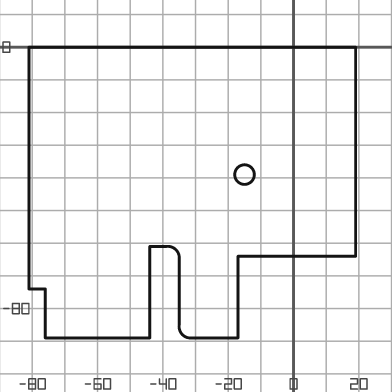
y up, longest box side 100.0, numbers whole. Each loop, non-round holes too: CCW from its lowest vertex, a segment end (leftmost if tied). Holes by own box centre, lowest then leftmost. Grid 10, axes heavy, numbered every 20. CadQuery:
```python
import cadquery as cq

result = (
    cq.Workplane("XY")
    .moveTo(-76.0, -89.0)
    .lineTo(-44.0, -89.0)
    .lineTo(-44.0, -61.0)
    .lineTo(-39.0, -61.0)
    .threePointArc((-36.0, -62.0), (-35.0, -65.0))
    .lineTo(-35.0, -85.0)
    .threePointArc((-34.0, -88.0), (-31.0, -89.0))
    .lineTo(-17.0, -89.0)
    .lineTo(-17.0, -64.0)
    .lineTo(19.0, -64.0)
    .lineTo(19.0, 0.0)
    .lineTo(-81.0, 0.0)
    .lineTo(-81.0, -74.0)
    .lineTo(-76.0, -74.0)
    .close()
    .moveTo(-15.0, -39.0)
    .circle(3.0)
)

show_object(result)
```